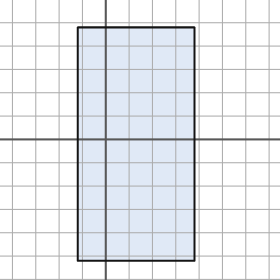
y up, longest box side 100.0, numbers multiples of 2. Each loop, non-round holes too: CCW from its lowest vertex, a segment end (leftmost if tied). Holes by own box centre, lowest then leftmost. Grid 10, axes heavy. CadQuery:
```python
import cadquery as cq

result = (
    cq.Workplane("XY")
    .moveTo(-12.0, -52.0)
    .lineTo(38.0, -52.0)
    .lineTo(38.0, 48.0)
    .lineTo(-12.0, 48.0)
    .close()
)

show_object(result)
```